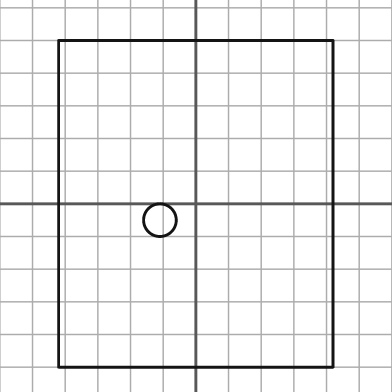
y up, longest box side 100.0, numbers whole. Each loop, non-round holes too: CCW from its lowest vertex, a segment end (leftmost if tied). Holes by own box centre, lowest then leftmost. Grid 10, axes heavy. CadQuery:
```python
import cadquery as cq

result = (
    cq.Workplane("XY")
    .moveTo(-42.0, -50.0)
    .lineTo(42.0, -50.0)
    .lineTo(42.0, 50.0)
    .lineTo(-42.0, 50.0)
    .close()
    .moveTo(-11.0, -5.0)
    .circle(5.0)
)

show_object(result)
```